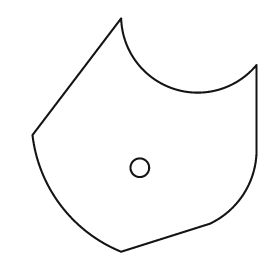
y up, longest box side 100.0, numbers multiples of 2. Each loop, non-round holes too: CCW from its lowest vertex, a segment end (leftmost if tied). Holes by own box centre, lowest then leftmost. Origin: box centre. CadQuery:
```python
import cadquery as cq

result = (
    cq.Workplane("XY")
    .moveTo(-10.0, -50.0)
    .lineTo(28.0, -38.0)
    .threePointArc((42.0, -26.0), (48.0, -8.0))
    .lineTo(48.0, 30.0)
    .threePointArc((12.0, 20.0), (-10.0, 50.0))
    .lineTo(-48.0, 0.0)
    .threePointArc((-36.0, -30.0), (-10.0, -50.0))
    .close()
    .moveTo(-2.0, -14.0)
    .circle(4.0)
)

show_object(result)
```